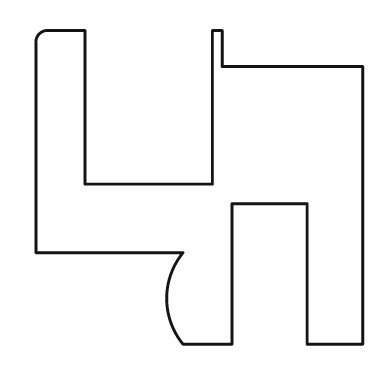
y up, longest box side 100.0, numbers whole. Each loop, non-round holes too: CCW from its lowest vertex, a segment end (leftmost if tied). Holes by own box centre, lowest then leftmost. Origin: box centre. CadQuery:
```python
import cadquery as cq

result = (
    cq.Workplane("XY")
    .moveTo(-5.0, -48.0)
    .lineTo(10.0, -48.0)
    .lineTo(10.0, -5.0)
    .lineTo(33.0, -5.0)
    .lineTo(33.0, -48.0)
    .lineTo(50.0, -48.0)
    .lineTo(50.0, 37.0)
    .lineTo(7.0, 37.0)
    .lineTo(7.0, 48.0)
    .lineTo(4.0, 48.0)
    .lineTo(4.0, 1.0)
    .lineTo(-35.0, 1.0)
    .lineTo(-35.0, 48.0)
    .lineTo(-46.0, 48.0)
    .threePointArc((-49.0, 47.0), (-50.0, 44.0))
    .lineTo(-50.0, -20.0)
    .lineTo(-5.0, -20.0)
    .threePointArc((-10.0, -34.0), (-5.0, -48.0))
    .close()
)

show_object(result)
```